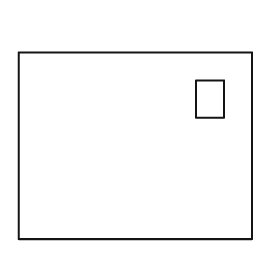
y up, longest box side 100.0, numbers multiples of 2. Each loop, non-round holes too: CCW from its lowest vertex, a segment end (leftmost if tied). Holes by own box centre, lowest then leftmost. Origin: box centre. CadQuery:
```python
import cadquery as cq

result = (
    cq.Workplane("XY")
    .moveTo(-50.0, -40.0)
    .lineTo(50.0, -40.0)
    .lineTo(50.0, 40.0)
    .lineTo(-50.0, 40.0)
    .close()
    .moveTo(26.0, 12.0)
    .lineTo(38.0, 12.0)
    .lineTo(38.0, 28.0)
    .lineTo(26.0, 28.0)
    .close()
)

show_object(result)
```